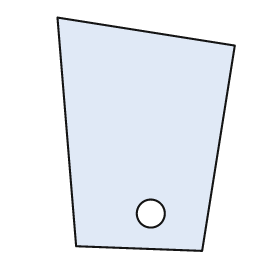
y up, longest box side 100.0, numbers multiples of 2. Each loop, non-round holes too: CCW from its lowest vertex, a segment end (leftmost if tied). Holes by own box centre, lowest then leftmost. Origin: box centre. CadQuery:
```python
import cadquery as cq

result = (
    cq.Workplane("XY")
    .moveTo(24.0, -50.0)
    .lineTo(38.0, 38.0)
    .lineTo(-38.0, 50.0)
    .lineTo(-30.0, -48.0)
    .close()
    .moveTo(2.0, -34.0)
    .circle(6.0)
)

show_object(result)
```